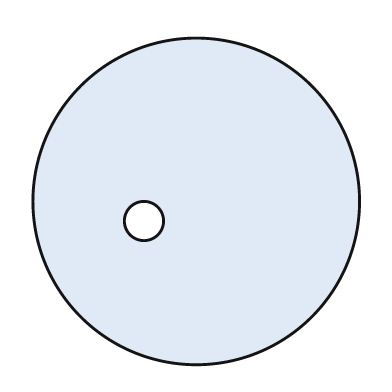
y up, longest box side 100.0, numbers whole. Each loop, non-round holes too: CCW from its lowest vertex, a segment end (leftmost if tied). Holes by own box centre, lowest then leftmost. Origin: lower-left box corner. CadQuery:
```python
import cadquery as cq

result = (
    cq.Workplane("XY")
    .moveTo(50.0, 50.0)
    .circle(50.0)
    .moveTo(34.0, 44.0)
    .circle(6.0)
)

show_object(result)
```